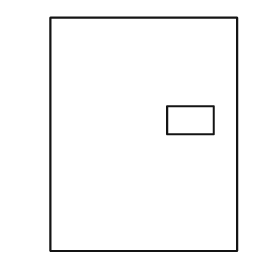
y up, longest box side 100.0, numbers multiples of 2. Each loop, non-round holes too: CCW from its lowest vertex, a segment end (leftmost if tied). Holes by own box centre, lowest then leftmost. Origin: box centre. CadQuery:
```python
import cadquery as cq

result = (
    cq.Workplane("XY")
    .moveTo(-40.0, -50.0)
    .lineTo(40.0, -50.0)
    .lineTo(40.0, 50.0)
    .lineTo(-40.0, 50.0)
    .close()
    .moveTo(10.0, 0.0)
    .lineTo(30.0, 0.0)
    .lineTo(30.0, 12.0)
    .lineTo(10.0, 12.0)
    .close()
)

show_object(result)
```